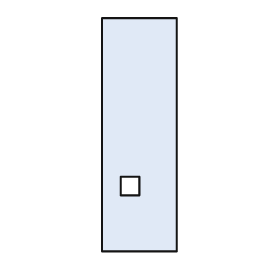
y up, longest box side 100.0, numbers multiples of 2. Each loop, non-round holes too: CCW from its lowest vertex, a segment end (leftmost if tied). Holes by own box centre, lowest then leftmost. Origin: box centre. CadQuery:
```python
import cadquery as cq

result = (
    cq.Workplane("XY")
    .moveTo(-16.0, -50.0)
    .lineTo(16.0, -50.0)
    .lineTo(16.0, 50.0)
    .lineTo(-16.0, 50.0)
    .close()
    .moveTo(-8.0, -26.0)
    .lineTo(0.0, -26.0)
    .lineTo(0.0, -18.0)
    .lineTo(-8.0, -18.0)
    .close()
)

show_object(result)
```